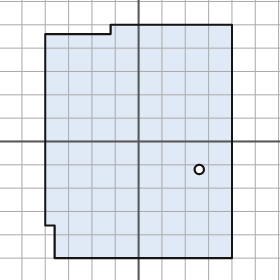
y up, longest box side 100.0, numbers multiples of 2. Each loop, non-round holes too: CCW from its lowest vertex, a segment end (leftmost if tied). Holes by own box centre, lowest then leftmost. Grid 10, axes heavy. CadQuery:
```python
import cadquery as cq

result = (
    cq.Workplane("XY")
    .moveTo(-36.0, -50.0)
    .lineTo(40.0, -50.0)
    .lineTo(40.0, 50.0)
    .lineTo(-12.0, 50.0)
    .lineTo(-12.0, 46.0)
    .lineTo(-40.0, 46.0)
    .lineTo(-40.0, -36.0)
    .lineTo(-36.0, -36.0)
    .close()
    .moveTo(26.0, -12.0)
    .circle(2.0)
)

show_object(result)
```